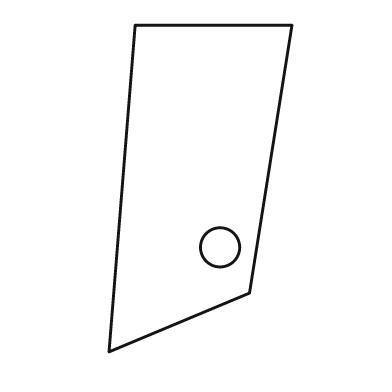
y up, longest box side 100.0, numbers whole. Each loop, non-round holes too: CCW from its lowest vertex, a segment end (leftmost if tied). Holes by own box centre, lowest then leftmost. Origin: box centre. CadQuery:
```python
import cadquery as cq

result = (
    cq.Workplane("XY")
    .moveTo(-28.0, -50.0)
    .lineTo(15.0, -32.0)
    .lineTo(28.0, 50.0)
    .lineTo(-20.0, 50.0)
    .close()
    .moveTo(6.0, -18.0)
    .circle(6.0)
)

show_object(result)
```